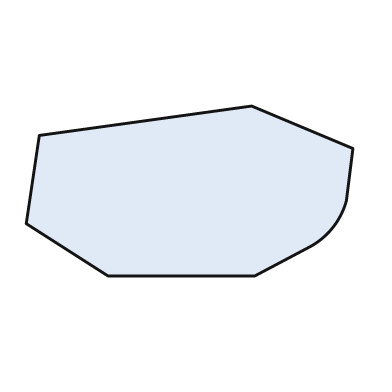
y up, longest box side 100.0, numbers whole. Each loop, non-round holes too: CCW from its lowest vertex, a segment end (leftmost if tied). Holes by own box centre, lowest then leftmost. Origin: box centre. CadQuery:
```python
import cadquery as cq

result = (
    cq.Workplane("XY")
    .moveTo(-25.0, -26.0)
    .lineTo(20.0, -26.0)
    .lineTo(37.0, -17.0)
    .threePointArc((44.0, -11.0), (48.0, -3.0))
    .lineTo(50.0, 13.0)
    .lineTo(19.0, 26.0)
    .lineTo(-46.0, 17.0)
    .lineTo(-50.0, -10.0)
    .close()
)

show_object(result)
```